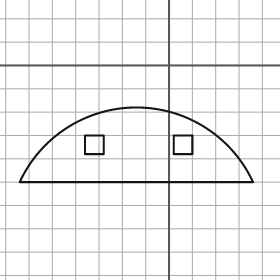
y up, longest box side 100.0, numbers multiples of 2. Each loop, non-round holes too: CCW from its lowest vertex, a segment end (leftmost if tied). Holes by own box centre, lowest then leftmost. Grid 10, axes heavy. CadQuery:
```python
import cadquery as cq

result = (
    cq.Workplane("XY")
    .moveTo(-64.0, -50.0)
    .lineTo(36.0, -50.0)
    .threePointArc((-14.0, -18.0), (-64.0, -50.0))
    .close()
    .moveTo(-36.0, -38.0)
    .lineTo(-28.0, -38.0)
    .lineTo(-28.0, -30.0)
    .lineTo(-36.0, -30.0)
    .close()
    .moveTo(2.0, -38.0)
    .lineTo(10.0, -38.0)
    .lineTo(10.0, -30.0)
    .lineTo(2.0, -30.0)
    .close()
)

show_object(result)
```